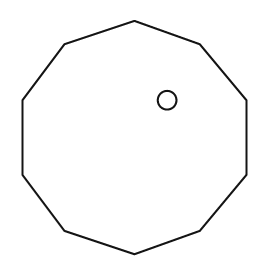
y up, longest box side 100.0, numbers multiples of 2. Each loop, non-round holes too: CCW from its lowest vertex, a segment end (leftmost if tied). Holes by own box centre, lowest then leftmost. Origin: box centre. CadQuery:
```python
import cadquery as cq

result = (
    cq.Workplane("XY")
    .moveTo(0.0, -50.0)
    .lineTo(28.0, -40.0)
    .lineTo(48.0, -16.0)
    .lineTo(48.0, 16.0)
    .lineTo(28.0, 40.0)
    .lineTo(0.0, 50.0)
    .lineTo(-30.0, 40.0)
    .lineTo(-48.0, 16.0)
    .lineTo(-48.0, -16.0)
    .lineTo(-30.0, -40.0)
    .close()
    .moveTo(14.0, 16.0)
    .circle(4.0)
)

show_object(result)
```